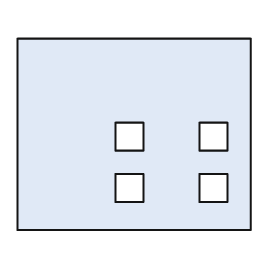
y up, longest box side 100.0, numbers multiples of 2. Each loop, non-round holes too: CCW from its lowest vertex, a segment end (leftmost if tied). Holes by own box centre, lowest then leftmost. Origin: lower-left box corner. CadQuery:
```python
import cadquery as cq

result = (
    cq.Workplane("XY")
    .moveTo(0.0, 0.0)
    .lineTo(100.0, 0.0)
    .lineTo(100.0, 82.0)
    .lineTo(0.0, 82.0)
    .close()
    .moveTo(42.0, 12.0)
    .lineTo(54.0, 12.0)
    .lineTo(54.0, 24.0)
    .lineTo(42.0, 24.0)
    .close()
    .moveTo(78.0, 12.0)
    .lineTo(90.0, 12.0)
    .lineTo(90.0, 24.0)
    .lineTo(78.0, 24.0)
    .close()
    .moveTo(42.0, 34.0)
    .lineTo(54.0, 34.0)
    .lineTo(54.0, 46.0)
    .lineTo(42.0, 46.0)
    .close()
    .moveTo(78.0, 34.0)
    .lineTo(90.0, 34.0)
    .lineTo(90.0, 46.0)
    .lineTo(78.0, 46.0)
    .close()
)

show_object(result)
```